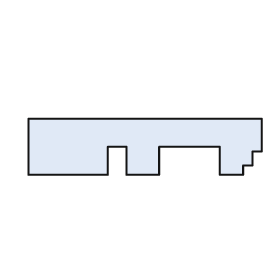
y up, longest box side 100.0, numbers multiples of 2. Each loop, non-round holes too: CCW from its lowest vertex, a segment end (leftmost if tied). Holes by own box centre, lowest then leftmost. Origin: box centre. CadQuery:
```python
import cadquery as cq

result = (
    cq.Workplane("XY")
    .moveTo(-50.0, -12.0)
    .lineTo(-16.0, -12.0)
    .lineTo(-16.0, 0.0)
    .lineTo(-8.0, 0.0)
    .lineTo(-8.0, -12.0)
    .lineTo(6.0, -12.0)
    .lineTo(6.0, 0.0)
    .lineTo(32.0, 0.0)
    .lineTo(32.0, -12.0)
    .lineTo(42.0, -12.0)
    .lineTo(42.0, -8.0)
    .lineTo(46.0, -8.0)
    .lineTo(46.0, -2.0)
    .lineTo(50.0, -2.0)
    .lineTo(50.0, 12.0)
    .lineTo(-50.0, 12.0)
    .close()
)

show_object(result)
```